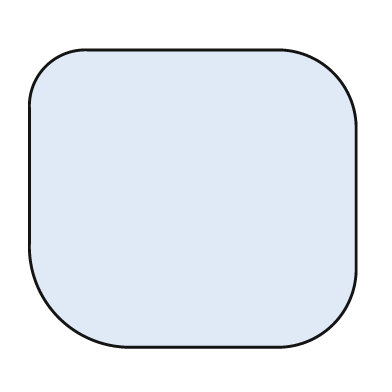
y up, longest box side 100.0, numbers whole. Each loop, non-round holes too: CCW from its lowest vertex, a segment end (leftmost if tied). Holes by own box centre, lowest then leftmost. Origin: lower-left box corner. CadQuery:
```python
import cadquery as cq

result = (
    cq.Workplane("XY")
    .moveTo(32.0, 0.0)
    .lineTo(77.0, 0.0)
    .threePointArc((93.0, 7.0), (100.0, 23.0))
    .lineTo(100.0, 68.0)
    .threePointArc((93.0, 84.0), (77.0, 91.0))
    .lineTo(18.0, 91.0)
    .threePointArc((5.0, 86.0), (0.0, 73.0))
    .lineTo(0.0, 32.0)
    .threePointArc((9.0, 9.0), (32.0, 0.0))
    .close()
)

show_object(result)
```